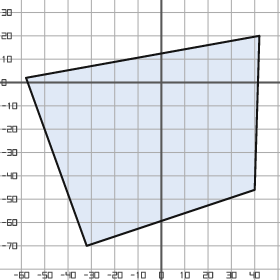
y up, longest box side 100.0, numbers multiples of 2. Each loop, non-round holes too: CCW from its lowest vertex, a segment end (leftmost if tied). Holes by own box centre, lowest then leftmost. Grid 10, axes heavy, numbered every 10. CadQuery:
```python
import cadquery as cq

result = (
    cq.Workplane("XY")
    .moveTo(-32.0, -70.0)
    .lineTo(40.0, -46.0)
    .lineTo(42.0, 20.0)
    .lineTo(-58.0, 2.0)
    .close()
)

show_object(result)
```